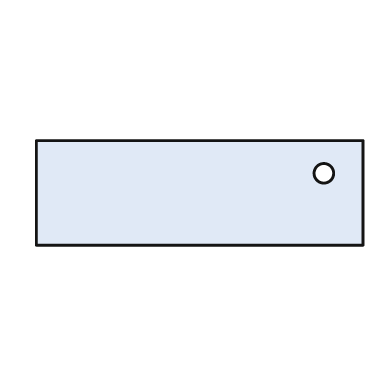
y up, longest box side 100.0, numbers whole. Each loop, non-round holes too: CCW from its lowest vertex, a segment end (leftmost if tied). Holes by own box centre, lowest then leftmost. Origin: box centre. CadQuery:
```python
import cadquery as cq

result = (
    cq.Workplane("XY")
    .moveTo(-50.0, -16.0)
    .lineTo(50.0, -16.0)
    .lineTo(50.0, 16.0)
    .lineTo(-50.0, 16.0)
    .close()
    .moveTo(38.0, 6.0)
    .circle(3.0)
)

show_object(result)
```